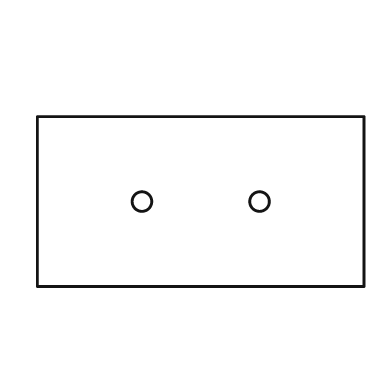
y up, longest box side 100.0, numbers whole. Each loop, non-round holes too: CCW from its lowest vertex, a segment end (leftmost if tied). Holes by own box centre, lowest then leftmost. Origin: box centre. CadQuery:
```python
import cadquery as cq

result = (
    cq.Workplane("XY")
    .moveTo(-50.0, -26.0)
    .lineTo(50.0, -26.0)
    .lineTo(50.0, 26.0)
    .lineTo(-50.0, 26.0)
    .close()
    .moveTo(-18.0, 0.0)
    .circle(3.0)
    .moveTo(18.0, 0.0)
    .circle(3.0)
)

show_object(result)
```